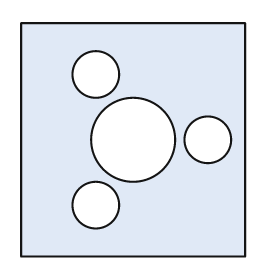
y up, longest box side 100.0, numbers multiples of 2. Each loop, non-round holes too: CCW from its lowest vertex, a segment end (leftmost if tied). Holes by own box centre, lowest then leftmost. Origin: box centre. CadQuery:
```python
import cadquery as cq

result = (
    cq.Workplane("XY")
    .moveTo(-48.0, -50.0)
    .lineTo(48.0, -50.0)
    .lineTo(48.0, 50.0)
    .lineTo(-48.0, 50.0)
    .close()
    .moveTo(-16.0, -28.0)
    .circle(10.0)
    .moveTo(0.0, 0.0)
    .circle(18.0)
    .moveTo(32.0, 0.0)
    .circle(10.0)
    .moveTo(-16.0, 28.0)
    .circle(10.0)
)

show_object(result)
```